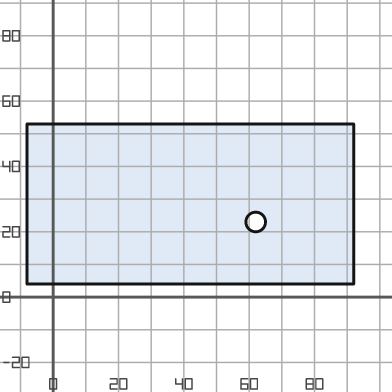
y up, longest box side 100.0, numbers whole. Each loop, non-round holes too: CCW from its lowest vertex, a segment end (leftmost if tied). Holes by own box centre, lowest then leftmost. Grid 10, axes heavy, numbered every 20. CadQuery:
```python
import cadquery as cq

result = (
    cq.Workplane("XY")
    .moveTo(-8.0, 4.0)
    .lineTo(92.0, 4.0)
    .lineTo(92.0, 53.0)
    .lineTo(-8.0, 53.0)
    .close()
    .moveTo(62.0, 23.0)
    .circle(3.0)
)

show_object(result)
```